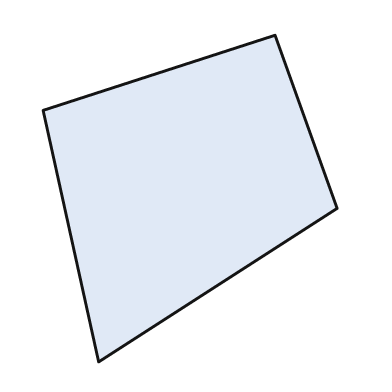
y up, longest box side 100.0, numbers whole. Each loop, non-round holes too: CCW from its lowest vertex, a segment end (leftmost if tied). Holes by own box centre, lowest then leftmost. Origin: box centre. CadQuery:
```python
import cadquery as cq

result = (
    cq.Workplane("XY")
    .moveTo(-28.0, -50.0)
    .lineTo(45.0, -3.0)
    .lineTo(26.0, 50.0)
    .lineTo(-45.0, 27.0)
    .close()
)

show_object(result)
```